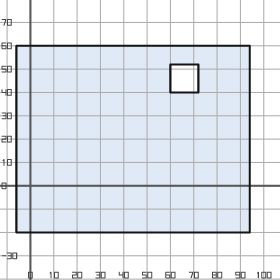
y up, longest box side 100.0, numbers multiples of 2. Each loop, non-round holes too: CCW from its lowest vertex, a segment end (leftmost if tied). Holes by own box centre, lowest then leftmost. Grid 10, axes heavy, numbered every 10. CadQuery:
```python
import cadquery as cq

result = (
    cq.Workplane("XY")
    .moveTo(-6.0, -20.0)
    .lineTo(94.0, -20.0)
    .lineTo(94.0, 60.0)
    .lineTo(-6.0, 60.0)
    .close()
    .moveTo(60.0, 40.0)
    .lineTo(72.0, 40.0)
    .lineTo(72.0, 52.0)
    .lineTo(60.0, 52.0)
    .close()
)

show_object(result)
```